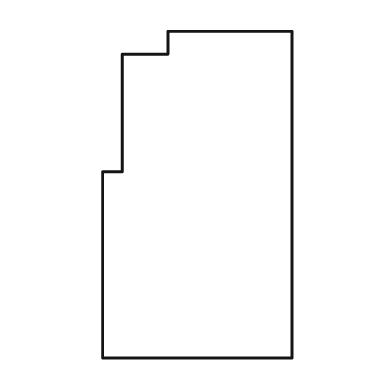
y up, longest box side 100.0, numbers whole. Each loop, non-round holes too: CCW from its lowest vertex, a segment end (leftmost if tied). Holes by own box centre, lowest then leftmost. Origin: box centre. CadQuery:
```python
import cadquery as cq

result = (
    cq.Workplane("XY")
    .moveTo(-29.0, -50.0)
    .lineTo(29.0, -50.0)
    .lineTo(29.0, 50.0)
    .lineTo(-9.0, 50.0)
    .lineTo(-9.0, 43.0)
    .lineTo(-23.0, 43.0)
    .lineTo(-23.0, 7.0)
    .lineTo(-29.0, 7.0)
    .close()
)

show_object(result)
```